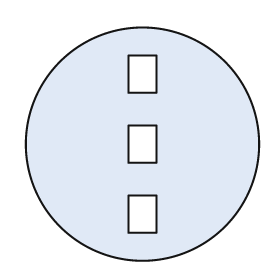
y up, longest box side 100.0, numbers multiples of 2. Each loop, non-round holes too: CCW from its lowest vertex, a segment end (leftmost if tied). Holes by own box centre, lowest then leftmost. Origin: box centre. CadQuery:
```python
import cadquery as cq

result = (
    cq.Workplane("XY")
    .moveTo(0.0, 0.0)
    .circle(50.0)
    .moveTo(-6.0, -38.0)
    .lineTo(6.0, -38.0)
    .lineTo(6.0, -22.0)
    .lineTo(-6.0, -22.0)
    .close()
    .moveTo(-6.0, -8.0)
    .lineTo(6.0, -8.0)
    .lineTo(6.0, 8.0)
    .lineTo(-6.0, 8.0)
    .close()
    .moveTo(-6.0, 22.0)
    .lineTo(6.0, 22.0)
    .lineTo(6.0, 38.0)
    .lineTo(-6.0, 38.0)
    .close()
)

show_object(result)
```